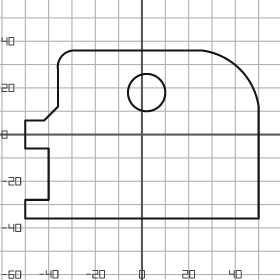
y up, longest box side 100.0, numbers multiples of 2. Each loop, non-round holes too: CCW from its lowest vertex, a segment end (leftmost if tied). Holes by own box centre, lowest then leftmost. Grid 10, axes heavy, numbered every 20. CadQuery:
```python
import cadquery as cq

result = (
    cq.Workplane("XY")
    .moveTo(-50.0, -36.0)
    .lineTo(50.0, -36.0)
    .lineTo(50.0, 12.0)
    .threePointArc((42.0, 28.0), (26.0, 36.0))
    .lineTo(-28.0, 36.0)
    .threePointArc((-34.0, 34.0), (-36.0, 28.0))
    .lineTo(-36.0, 12.0)
    .lineTo(-42.0, 6.0)
    .lineTo(-50.0, 6.0)
    .lineTo(-50.0, -6.0)
    .lineTo(-40.0, -6.0)
    .lineTo(-40.0, -28.0)
    .lineTo(-50.0, -28.0)
    .close()
    .moveTo(2.0, 18.0)
    .circle(8.0)
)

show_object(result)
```